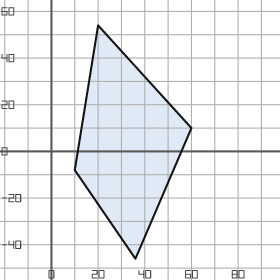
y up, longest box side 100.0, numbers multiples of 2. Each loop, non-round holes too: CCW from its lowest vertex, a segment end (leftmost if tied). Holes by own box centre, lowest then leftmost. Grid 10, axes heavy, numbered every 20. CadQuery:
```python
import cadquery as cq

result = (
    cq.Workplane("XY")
    .moveTo(36.0, -46.0)
    .lineTo(60.0, 10.0)
    .lineTo(20.0, 54.0)
    .lineTo(10.0, -8.0)
    .close()
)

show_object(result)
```